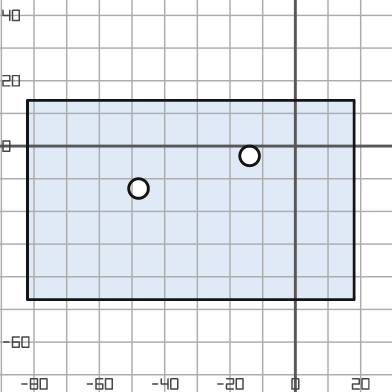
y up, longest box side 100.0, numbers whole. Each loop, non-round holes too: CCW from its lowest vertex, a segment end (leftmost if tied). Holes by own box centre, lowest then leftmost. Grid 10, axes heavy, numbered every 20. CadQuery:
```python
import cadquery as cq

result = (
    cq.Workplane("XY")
    .moveTo(-82.0, -47.0)
    .lineTo(18.0, -47.0)
    .lineTo(18.0, 14.0)
    .lineTo(-82.0, 14.0)
    .close()
    .moveTo(-48.0, -13.0)
    .circle(3.0)
    .moveTo(-14.0, -3.0)
    .circle(3.0)
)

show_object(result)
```